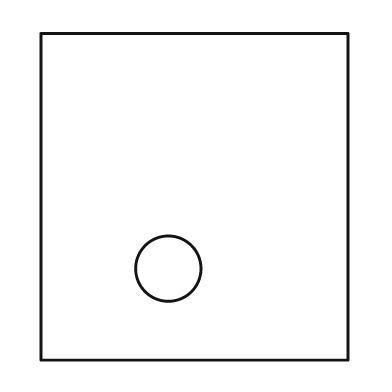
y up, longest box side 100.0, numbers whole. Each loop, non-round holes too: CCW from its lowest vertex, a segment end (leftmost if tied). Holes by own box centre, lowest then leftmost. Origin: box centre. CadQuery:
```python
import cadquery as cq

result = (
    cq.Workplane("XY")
    .moveTo(-47.0, -50.0)
    .lineTo(47.0, -50.0)
    .lineTo(47.0, 50.0)
    .lineTo(-47.0, 50.0)
    .close()
    .moveTo(-8.0, -22.0)
    .circle(10.0)
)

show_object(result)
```